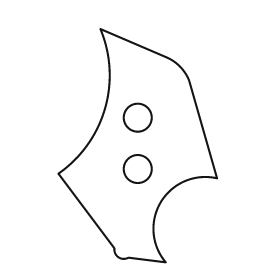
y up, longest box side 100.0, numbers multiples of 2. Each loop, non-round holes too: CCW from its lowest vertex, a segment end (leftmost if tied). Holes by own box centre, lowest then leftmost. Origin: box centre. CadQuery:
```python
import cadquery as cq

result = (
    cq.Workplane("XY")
    .moveTo(12.0, -50.0)
    .threePointArc((10.0, -24.0), (34.0, -14.0))
    .lineTo(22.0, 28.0)
    .threePointArc((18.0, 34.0), (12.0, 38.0))
    .lineTo(-16.0, 50.0)
    .threePointArc((-14.0, 16.0), (-34.0, -12.0))
    .lineTo(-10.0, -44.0)
    .threePointArc((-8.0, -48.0), (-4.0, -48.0))
    .close()
    .moveTo(0.0, -10.0)
    .circle(6.0)
    .moveTo(0.0, 12.0)
    .circle(6.0)
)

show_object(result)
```